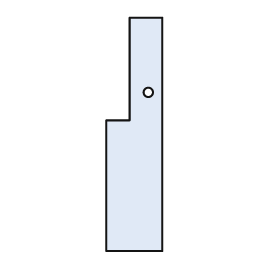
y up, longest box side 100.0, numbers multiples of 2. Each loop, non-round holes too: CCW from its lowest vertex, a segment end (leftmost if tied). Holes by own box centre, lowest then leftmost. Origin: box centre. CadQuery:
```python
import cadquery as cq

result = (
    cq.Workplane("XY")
    .moveTo(-12.0, -50.0)
    .lineTo(12.0, -50.0)
    .lineTo(12.0, 50.0)
    .lineTo(-2.0, 50.0)
    .lineTo(-2.0, 6.0)
    .lineTo(-12.0, 6.0)
    .close()
    .moveTo(6.0, 18.0)
    .circle(2.0)
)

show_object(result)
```